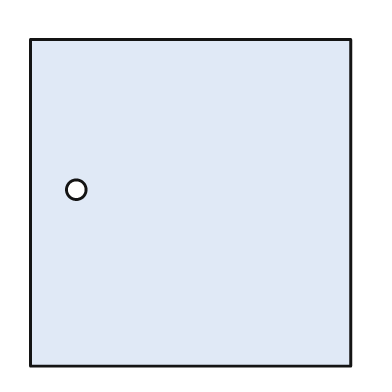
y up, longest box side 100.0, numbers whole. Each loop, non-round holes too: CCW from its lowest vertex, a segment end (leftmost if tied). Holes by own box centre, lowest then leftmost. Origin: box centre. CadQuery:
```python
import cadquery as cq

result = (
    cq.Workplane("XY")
    .moveTo(-49.0, -50.0)
    .lineTo(49.0, -50.0)
    .lineTo(49.0, 50.0)
    .lineTo(-49.0, 50.0)
    .close()
    .moveTo(-35.0, 4.0)
    .circle(3.0)
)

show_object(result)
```